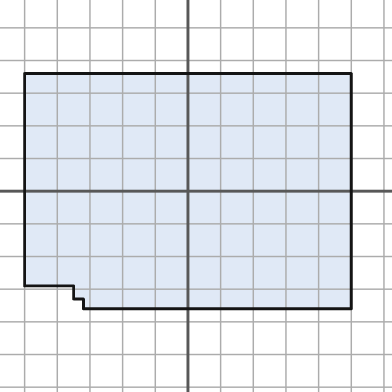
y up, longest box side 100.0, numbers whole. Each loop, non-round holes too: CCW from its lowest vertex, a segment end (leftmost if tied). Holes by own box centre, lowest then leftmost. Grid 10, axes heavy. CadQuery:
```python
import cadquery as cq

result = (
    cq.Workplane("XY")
    .moveTo(-32.0, -36.0)
    .lineTo(50.0, -36.0)
    .lineTo(50.0, 36.0)
    .lineTo(-50.0, 36.0)
    .lineTo(-50.0, -29.0)
    .lineTo(-35.0, -29.0)
    .lineTo(-35.0, -33.0)
    .lineTo(-32.0, -33.0)
    .close()
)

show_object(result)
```